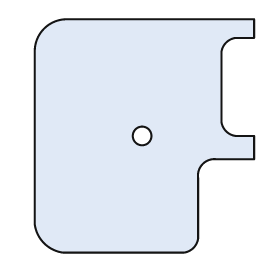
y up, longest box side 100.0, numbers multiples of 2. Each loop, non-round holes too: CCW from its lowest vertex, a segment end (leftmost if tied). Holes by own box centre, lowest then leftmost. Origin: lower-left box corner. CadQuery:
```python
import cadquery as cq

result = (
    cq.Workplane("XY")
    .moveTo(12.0, 0.0)
    .lineTo(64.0, 0.0)
    .threePointArc((68.0, 2.0), (70.0, 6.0))
    .lineTo(70.0, 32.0)
    .threePointArc((72.0, 38.0), (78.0, 40.0))
    .lineTo(94.0, 40.0)
    .lineTo(94.0, 50.0)
    .lineTo(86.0, 50.0)
    .threePointArc((82.0, 52.0), (80.0, 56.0))
    .lineTo(80.0, 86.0)
    .threePointArc((82.0, 90.0), (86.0, 92.0))
    .lineTo(94.0, 92.0)
    .lineTo(94.0, 100.0)
    .lineTo(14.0, 100.0)
    .threePointArc((4.0, 96.0), (0.0, 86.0))
    .lineTo(0.0, 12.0)
    .threePointArc((4.0, 4.0), (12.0, 0.0))
    .close()
    .moveTo(46.0, 50.0)
    .circle(4.0)
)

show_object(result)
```